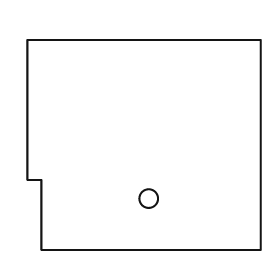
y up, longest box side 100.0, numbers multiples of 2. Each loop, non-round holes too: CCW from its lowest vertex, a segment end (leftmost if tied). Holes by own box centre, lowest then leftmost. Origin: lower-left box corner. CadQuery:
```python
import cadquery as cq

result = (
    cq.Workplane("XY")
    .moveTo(6.0, 0.0)
    .lineTo(100.0, 0.0)
    .lineTo(100.0, 90.0)
    .lineTo(0.0, 90.0)
    .lineTo(0.0, 30.0)
    .lineTo(6.0, 30.0)
    .close()
    .moveTo(52.0, 22.0)
    .circle(4.0)
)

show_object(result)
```